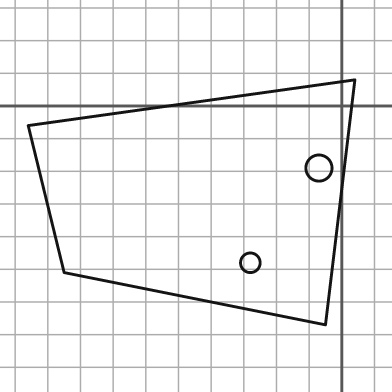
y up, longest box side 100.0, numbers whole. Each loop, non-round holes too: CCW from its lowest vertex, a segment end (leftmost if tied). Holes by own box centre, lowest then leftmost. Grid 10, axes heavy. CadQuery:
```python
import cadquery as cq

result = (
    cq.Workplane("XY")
    .moveTo(-5.0, -67.0)
    .lineTo(4.0, 8.0)
    .lineTo(-96.0, -6.0)
    .lineTo(-85.0, -51.0)
    .close()
    .moveTo(-28.0, -48.0)
    .circle(3.0)
    .moveTo(-7.0, -19.0)
    .circle(4.0)
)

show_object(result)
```